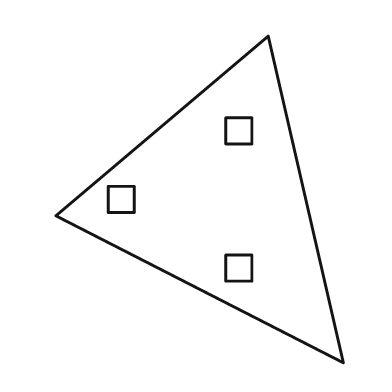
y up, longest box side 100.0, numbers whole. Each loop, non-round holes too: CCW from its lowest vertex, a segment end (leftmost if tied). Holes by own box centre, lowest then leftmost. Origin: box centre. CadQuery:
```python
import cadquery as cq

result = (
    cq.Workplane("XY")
    .moveTo(44.0, -50.0)
    .lineTo(21.0, 50.0)
    .lineTo(-44.0, -5.0)
    .close()
    .moveTo(8.0, -25.0)
    .lineTo(16.0, -25.0)
    .lineTo(16.0, -17.0)
    .lineTo(8.0, -17.0)
    .close()
    .moveTo(-28.0, -4.0)
    .lineTo(-20.0, -4.0)
    .lineTo(-20.0, 4.0)
    .lineTo(-28.0, 4.0)
    .close()
    .moveTo(8.0, 17.0)
    .lineTo(16.0, 17.0)
    .lineTo(16.0, 25.0)
    .lineTo(8.0, 25.0)
    .close()
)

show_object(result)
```